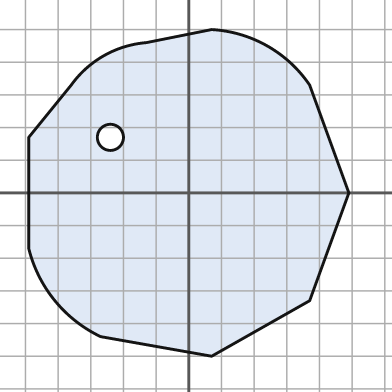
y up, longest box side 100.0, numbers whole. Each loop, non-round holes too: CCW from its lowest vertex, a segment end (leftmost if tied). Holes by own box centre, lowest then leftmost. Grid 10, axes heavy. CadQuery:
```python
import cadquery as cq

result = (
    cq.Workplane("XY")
    .moveTo(7.0, -50.0)
    .lineTo(37.0, -33.0)
    .lineTo(49.0, 0.0)
    .lineTo(37.0, 33.0)
    .threePointArc((24.0, 45.0), (7.0, 50.0))
    .lineTo(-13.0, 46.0)
    .threePointArc((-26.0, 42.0), (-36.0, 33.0))
    .lineTo(-49.0, 17.0)
    .lineTo(-49.0, -17.0)
    .threePointArc((-41.0, -33.0), (-27.0, -44.0))
    .close()
    .moveTo(-24.0, 17.0)
    .circle(4.0)
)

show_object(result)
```